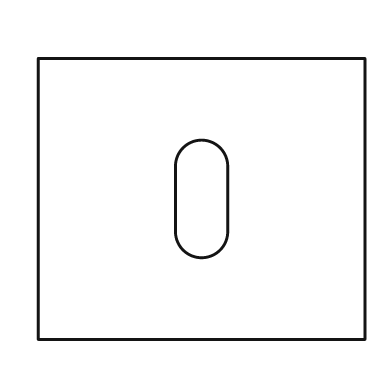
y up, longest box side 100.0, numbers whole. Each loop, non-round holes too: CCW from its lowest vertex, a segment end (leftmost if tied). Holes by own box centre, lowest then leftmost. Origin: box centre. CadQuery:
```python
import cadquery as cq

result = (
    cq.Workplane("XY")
    .moveTo(-50.0, -43.0)
    .lineTo(50.0, -43.0)
    .lineTo(50.0, 43.0)
    .lineTo(-50.0, 43.0)
    .close()
    .moveTo(-8.0, -10.0)
    .threePointArc((0.0, -18.0), (8.0, -10.0))
    .lineTo(8.0, 10.0)
    .threePointArc((0.0, 18.0), (-8.0, 10.0))
    .close()
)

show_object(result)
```